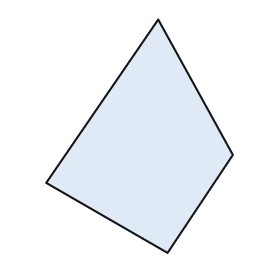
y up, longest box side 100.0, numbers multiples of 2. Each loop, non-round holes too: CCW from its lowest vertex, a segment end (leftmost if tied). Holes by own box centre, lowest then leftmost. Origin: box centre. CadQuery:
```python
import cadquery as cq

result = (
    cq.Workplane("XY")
    .moveTo(12.0, -50.0)
    .lineTo(40.0, -8.0)
    .lineTo(8.0, 50.0)
    .lineTo(-40.0, -20.0)
    .close()
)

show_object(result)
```